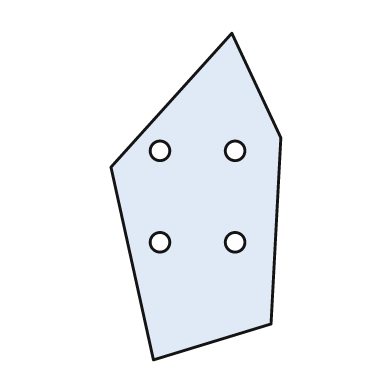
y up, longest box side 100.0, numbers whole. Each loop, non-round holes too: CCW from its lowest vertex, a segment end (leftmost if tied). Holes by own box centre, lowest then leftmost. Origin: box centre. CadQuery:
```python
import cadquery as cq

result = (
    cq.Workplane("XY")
    .moveTo(-13.0, -50.0)
    .lineTo(23.0, -39.0)
    .lineTo(26.0, 18.0)
    .lineTo(11.0, 50.0)
    .lineTo(-26.0, 9.0)
    .close()
    .moveTo(-11.0, -14.0)
    .circle(3.0)
    .moveTo(12.0, -14.0)
    .circle(3.0)
    .moveTo(-11.0, 14.0)
    .circle(3.0)
    .moveTo(12.0, 14.0)
    .circle(3.0)
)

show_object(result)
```